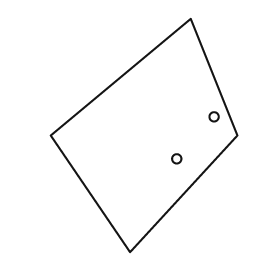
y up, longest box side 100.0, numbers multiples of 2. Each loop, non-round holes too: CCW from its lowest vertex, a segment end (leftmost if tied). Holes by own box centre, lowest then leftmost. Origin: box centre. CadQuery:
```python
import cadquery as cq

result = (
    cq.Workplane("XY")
    .moveTo(-6.0, -50.0)
    .lineTo(40.0, 0.0)
    .lineTo(20.0, 50.0)
    .lineTo(-40.0, 0.0)
    .close()
    .moveTo(14.0, -10.0)
    .circle(2.0)
    .moveTo(30.0, 8.0)
    .circle(2.0)
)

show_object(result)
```